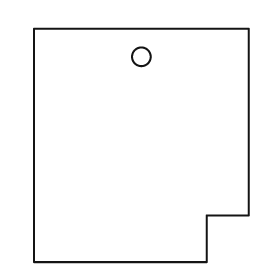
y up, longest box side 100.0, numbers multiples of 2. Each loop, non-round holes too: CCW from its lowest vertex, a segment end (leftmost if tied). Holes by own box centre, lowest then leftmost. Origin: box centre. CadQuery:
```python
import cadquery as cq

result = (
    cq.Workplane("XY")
    .moveTo(-46.0, -50.0)
    .lineTo(28.0, -50.0)
    .lineTo(28.0, -30.0)
    .lineTo(46.0, -30.0)
    .lineTo(46.0, 50.0)
    .lineTo(-46.0, 50.0)
    .close()
    .moveTo(0.0, 38.0)
    .circle(4.0)
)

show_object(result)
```